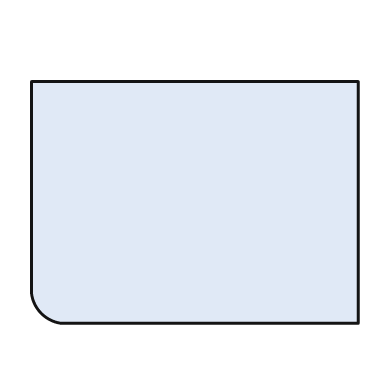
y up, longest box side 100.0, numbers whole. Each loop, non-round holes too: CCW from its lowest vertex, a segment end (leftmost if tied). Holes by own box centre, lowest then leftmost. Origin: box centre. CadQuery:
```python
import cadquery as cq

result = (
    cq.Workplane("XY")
    .moveTo(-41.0, -37.0)
    .lineTo(50.0, -37.0)
    .lineTo(50.0, 37.0)
    .lineTo(-50.0, 37.0)
    .lineTo(-50.0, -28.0)
    .threePointArc((-47.0, -34.0), (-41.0, -37.0))
    .close()
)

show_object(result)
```